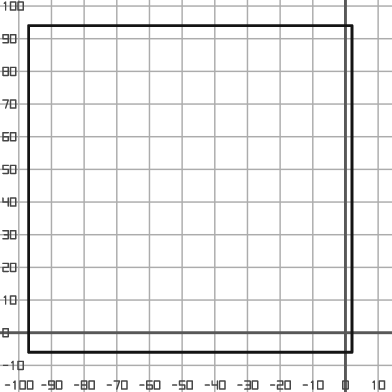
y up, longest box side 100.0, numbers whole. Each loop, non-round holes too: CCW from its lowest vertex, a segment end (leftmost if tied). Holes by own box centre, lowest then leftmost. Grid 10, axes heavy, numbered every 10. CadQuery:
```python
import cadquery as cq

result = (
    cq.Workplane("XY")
    .moveTo(-97.0, -6.0)
    .lineTo(2.0, -6.0)
    .lineTo(2.0, 94.0)
    .lineTo(-97.0, 94.0)
    .close()
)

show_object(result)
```